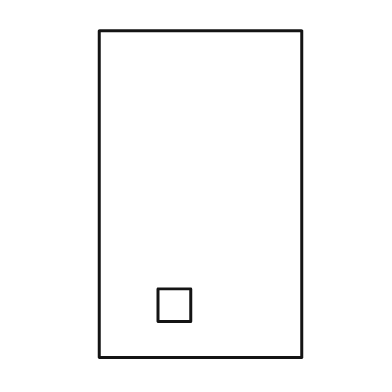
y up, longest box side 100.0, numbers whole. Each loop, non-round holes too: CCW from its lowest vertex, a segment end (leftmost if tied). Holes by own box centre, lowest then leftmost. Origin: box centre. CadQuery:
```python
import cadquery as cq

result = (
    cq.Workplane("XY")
    .moveTo(-31.0, -50.0)
    .lineTo(31.0, -50.0)
    .lineTo(31.0, 50.0)
    .lineTo(-31.0, 50.0)
    .close()
    .moveTo(-13.0, -39.0)
    .lineTo(-3.0, -39.0)
    .lineTo(-3.0, -29.0)
    .lineTo(-13.0, -29.0)
    .close()
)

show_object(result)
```